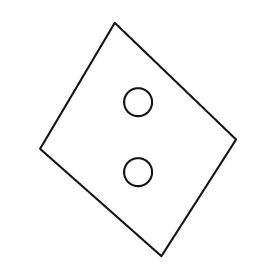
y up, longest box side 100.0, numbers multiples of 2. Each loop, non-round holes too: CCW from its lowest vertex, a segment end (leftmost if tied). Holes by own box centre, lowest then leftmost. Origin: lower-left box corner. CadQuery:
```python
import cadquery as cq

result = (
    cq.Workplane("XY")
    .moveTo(52.0, 0.0)
    .lineTo(84.0, 50.0)
    .lineTo(32.0, 100.0)
    .lineTo(0.0, 46.0)
    .close()
    .moveTo(42.0, 36.0)
    .circle(6.0)
    .moveTo(42.0, 66.0)
    .circle(6.0)
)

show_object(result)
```